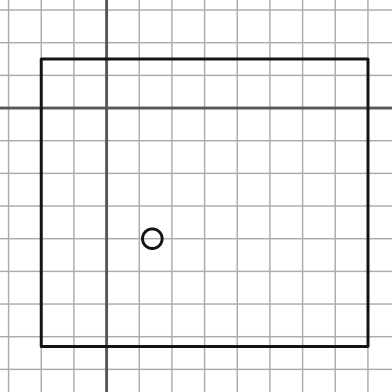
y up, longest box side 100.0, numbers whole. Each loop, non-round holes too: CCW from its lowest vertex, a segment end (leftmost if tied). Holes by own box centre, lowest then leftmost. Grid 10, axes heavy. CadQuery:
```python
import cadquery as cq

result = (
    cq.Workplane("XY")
    .moveTo(-20.0, -73.0)
    .lineTo(80.0, -73.0)
    .lineTo(80.0, 15.0)
    .lineTo(-20.0, 15.0)
    .close()
    .moveTo(14.0, -40.0)
    .circle(3.0)
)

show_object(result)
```